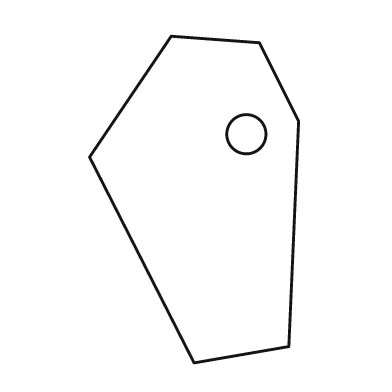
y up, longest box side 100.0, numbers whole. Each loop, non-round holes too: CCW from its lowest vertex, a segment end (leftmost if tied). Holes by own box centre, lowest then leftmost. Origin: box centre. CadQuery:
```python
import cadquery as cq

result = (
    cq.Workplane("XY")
    .moveTo(0.0, -50.0)
    .lineTo(29.0, -45.0)
    .lineTo(32.0, 24.0)
    .lineTo(20.0, 48.0)
    .lineTo(-7.0, 50.0)
    .lineTo(-32.0, 13.0)
    .close()
    .moveTo(16.0, 20.0)
    .circle(6.0)
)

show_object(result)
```